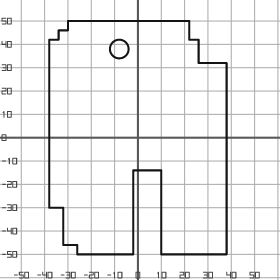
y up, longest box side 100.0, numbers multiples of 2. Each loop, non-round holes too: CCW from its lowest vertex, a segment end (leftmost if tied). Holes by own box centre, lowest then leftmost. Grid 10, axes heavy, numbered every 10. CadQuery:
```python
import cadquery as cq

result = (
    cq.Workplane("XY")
    .moveTo(-26.0, -50.0)
    .lineTo(-2.0, -50.0)
    .lineTo(-2.0, -14.0)
    .lineTo(10.0, -14.0)
    .lineTo(10.0, -50.0)
    .lineTo(38.0, -50.0)
    .lineTo(38.0, 32.0)
    .lineTo(26.0, 32.0)
    .lineTo(26.0, 42.0)
    .lineTo(22.0, 42.0)
    .lineTo(22.0, 50.0)
    .lineTo(-30.0, 50.0)
    .lineTo(-30.0, 46.0)
    .lineTo(-34.0, 46.0)
    .lineTo(-34.0, 42.0)
    .lineTo(-38.0, 42.0)
    .lineTo(-38.0, -30.0)
    .lineTo(-32.0, -30.0)
    .lineTo(-32.0, -46.0)
    .lineTo(-26.0, -46.0)
    .close()
    .moveTo(-8.0, 38.0)
    .circle(4.0)
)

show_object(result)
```